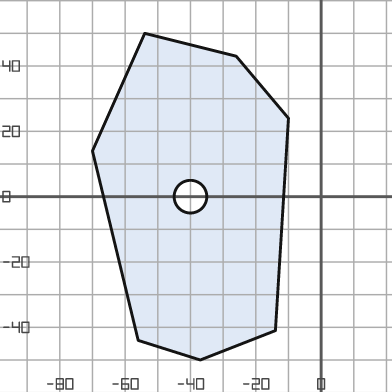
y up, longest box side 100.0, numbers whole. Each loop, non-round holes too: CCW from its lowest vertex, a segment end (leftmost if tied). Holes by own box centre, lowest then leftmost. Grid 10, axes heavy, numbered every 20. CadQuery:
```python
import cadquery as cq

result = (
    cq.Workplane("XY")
    .moveTo(-37.0, -50.0)
    .lineTo(-14.0, -41.0)
    .lineTo(-10.0, 24.0)
    .lineTo(-26.0, 43.0)
    .lineTo(-54.0, 50.0)
    .lineTo(-70.0, 14.0)
    .lineTo(-56.0, -44.0)
    .close()
    .moveTo(-40.0, 0.0)
    .circle(5.0)
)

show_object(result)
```